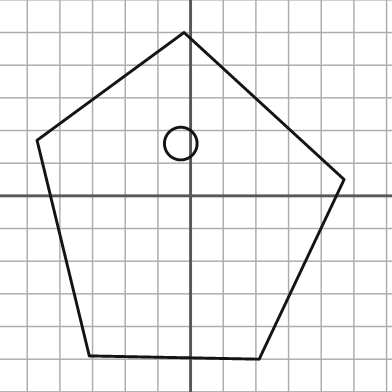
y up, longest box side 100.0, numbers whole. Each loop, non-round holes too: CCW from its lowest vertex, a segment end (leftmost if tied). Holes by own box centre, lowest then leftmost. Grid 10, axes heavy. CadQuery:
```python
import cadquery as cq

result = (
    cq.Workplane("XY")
    .moveTo(21.0, -50.0)
    .lineTo(47.0, 5.0)
    .lineTo(-2.0, 50.0)
    .lineTo(-47.0, 17.0)
    .lineTo(-31.0, -49.0)
    .close()
    .moveTo(-3.0, 16.0)
    .circle(5.0)
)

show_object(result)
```